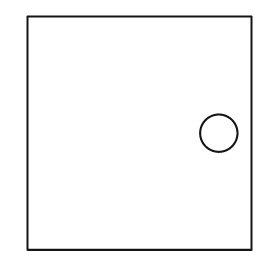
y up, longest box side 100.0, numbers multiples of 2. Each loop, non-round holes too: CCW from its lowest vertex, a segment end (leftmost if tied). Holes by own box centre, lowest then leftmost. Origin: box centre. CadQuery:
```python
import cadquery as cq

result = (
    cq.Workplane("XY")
    .moveTo(-48.0, -50.0)
    .lineTo(48.0, -50.0)
    .lineTo(48.0, 50.0)
    .lineTo(-48.0, 50.0)
    .close()
    .moveTo(34.0, 0.0)
    .circle(8.0)
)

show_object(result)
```